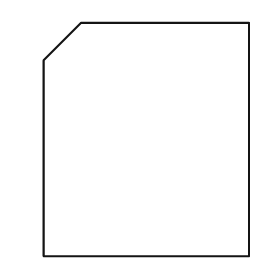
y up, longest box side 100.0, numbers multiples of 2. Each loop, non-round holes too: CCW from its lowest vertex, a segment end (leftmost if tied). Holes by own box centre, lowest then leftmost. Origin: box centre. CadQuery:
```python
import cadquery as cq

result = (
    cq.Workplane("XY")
    .moveTo(-44.0, -50.0)
    .lineTo(44.0, -50.0)
    .lineTo(44.0, 50.0)
    .lineTo(-28.0, 50.0)
    .lineTo(-44.0, 34.0)
    .close()
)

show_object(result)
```